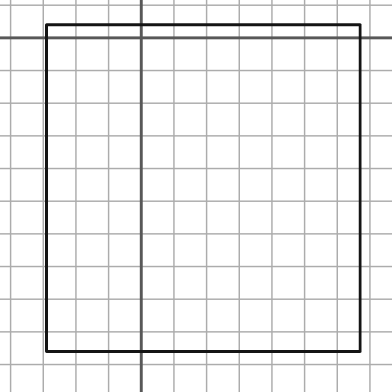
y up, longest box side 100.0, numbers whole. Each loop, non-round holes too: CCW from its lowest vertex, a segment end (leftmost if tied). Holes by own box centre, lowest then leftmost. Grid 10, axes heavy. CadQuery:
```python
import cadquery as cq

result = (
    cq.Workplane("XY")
    .moveTo(-29.0, -96.0)
    .lineTo(67.0, -96.0)
    .lineTo(67.0, 4.0)
    .lineTo(-29.0, 4.0)
    .close()
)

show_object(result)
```